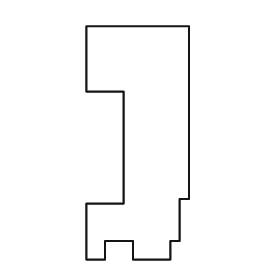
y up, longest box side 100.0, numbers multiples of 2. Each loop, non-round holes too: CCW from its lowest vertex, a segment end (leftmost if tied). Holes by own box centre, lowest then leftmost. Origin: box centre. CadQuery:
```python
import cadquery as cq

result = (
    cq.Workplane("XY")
    .moveTo(-22.0, -50.0)
    .lineTo(-14.0, -50.0)
    .lineTo(-14.0, -42.0)
    .lineTo(-2.0, -42.0)
    .lineTo(-2.0, -50.0)
    .lineTo(14.0, -50.0)
    .lineTo(14.0, -42.0)
    .lineTo(18.0, -42.0)
    .lineTo(18.0, -24.0)
    .lineTo(22.0, -24.0)
    .lineTo(22.0, 50.0)
    .lineTo(-22.0, 50.0)
    .lineTo(-22.0, 22.0)
    .lineTo(-6.0, 22.0)
    .lineTo(-6.0, -26.0)
    .lineTo(-22.0, -26.0)
    .close()
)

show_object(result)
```